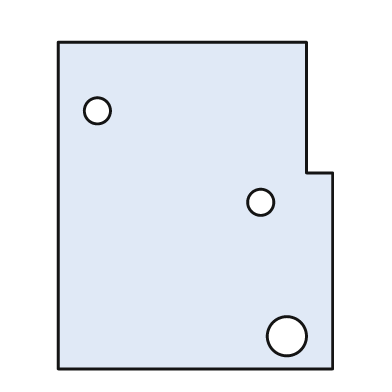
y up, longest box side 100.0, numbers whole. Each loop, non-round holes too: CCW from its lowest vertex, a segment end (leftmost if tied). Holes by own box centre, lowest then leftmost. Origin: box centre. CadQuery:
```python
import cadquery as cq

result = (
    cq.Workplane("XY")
    .moveTo(-42.0, -50.0)
    .lineTo(42.0, -50.0)
    .lineTo(42.0, 10.0)
    .lineTo(34.0, 10.0)
    .lineTo(34.0, 50.0)
    .lineTo(-42.0, 50.0)
    .close()
    .moveTo(28.0, -40.0)
    .circle(6.0)
    .moveTo(20.0, 1.0)
    .circle(4.0)
    .moveTo(-30.0, 29.0)
    .circle(4.0)
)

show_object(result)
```